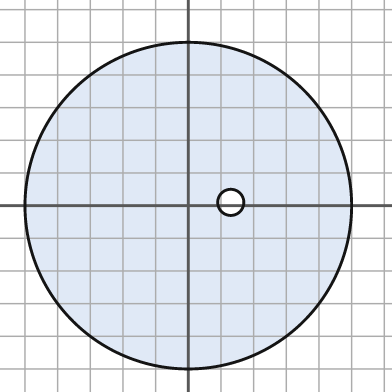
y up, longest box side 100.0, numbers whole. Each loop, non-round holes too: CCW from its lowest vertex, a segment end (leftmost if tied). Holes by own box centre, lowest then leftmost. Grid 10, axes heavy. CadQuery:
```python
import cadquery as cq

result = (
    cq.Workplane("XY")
    .moveTo(0.0, 0.0)
    .circle(50.0)
    .moveTo(13.0, 1.0)
    .circle(4.0)
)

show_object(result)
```